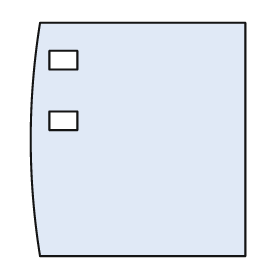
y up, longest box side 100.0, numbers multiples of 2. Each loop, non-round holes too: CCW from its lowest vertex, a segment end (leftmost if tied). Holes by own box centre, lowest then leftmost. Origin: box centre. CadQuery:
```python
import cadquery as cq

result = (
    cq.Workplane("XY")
    .moveTo(-42.0, -50.0)
    .lineTo(46.0, -50.0)
    .lineTo(46.0, 50.0)
    .lineTo(-42.0, 50.0)
    .threePointArc((-46.0, 0.0), (-42.0, -50.0))
    .close()
    .moveTo(-38.0, 4.0)
    .lineTo(-26.0, 4.0)
    .lineTo(-26.0, 12.0)
    .lineTo(-38.0, 12.0)
    .close()
    .moveTo(-38.0, 30.0)
    .lineTo(-26.0, 30.0)
    .lineTo(-26.0, 38.0)
    .lineTo(-38.0, 38.0)
    .close()
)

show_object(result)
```